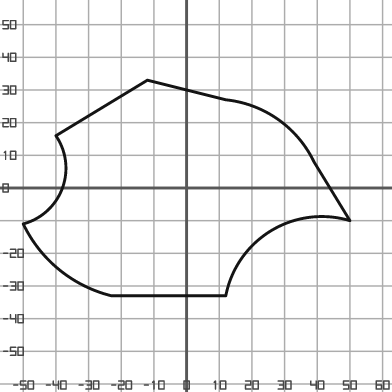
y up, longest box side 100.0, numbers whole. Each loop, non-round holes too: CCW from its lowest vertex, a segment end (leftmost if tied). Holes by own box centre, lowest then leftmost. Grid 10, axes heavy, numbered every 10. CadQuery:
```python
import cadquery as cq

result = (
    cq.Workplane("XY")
    .moveTo(-23.0, -33.0)
    .lineTo(12.0, -33.0)
    .threePointArc((26.0, -13.0), (50.0, -10.0))
    .lineTo(39.0, 8.0)
    .threePointArc((28.0, 21.0), (12.0, 27.0))
    .lineTo(-12.0, 33.0)
    .lineTo(-40.0, 16.0)
    .threePointArc((-38.0, 0.0), (-50.0, -11.0))
    .threePointArc((-39.0, -25.0), (-23.0, -33.0))
    .close()
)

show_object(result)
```